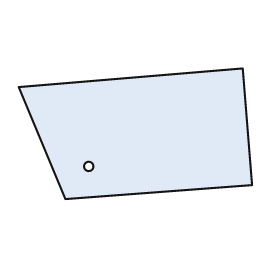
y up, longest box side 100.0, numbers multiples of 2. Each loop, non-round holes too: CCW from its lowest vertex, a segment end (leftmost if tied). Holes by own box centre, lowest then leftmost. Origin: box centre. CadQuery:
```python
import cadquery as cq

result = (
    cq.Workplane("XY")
    .moveTo(-30.0, -28.0)
    .lineTo(50.0, -22.0)
    .lineTo(46.0, 28.0)
    .lineTo(-50.0, 20.0)
    .close()
    .moveTo(-20.0, -14.0)
    .circle(2.0)
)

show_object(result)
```